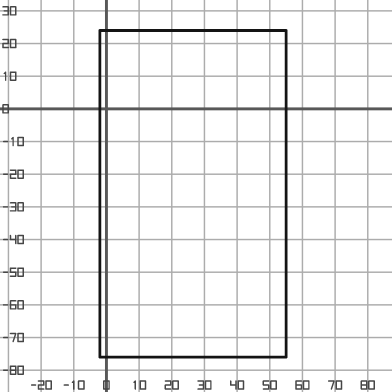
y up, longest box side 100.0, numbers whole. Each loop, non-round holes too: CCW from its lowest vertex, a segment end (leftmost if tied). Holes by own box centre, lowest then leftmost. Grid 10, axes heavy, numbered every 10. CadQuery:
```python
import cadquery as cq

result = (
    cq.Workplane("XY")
    .moveTo(-2.0, -76.0)
    .lineTo(55.0, -76.0)
    .lineTo(55.0, 24.0)
    .lineTo(-2.0, 24.0)
    .close()
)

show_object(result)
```